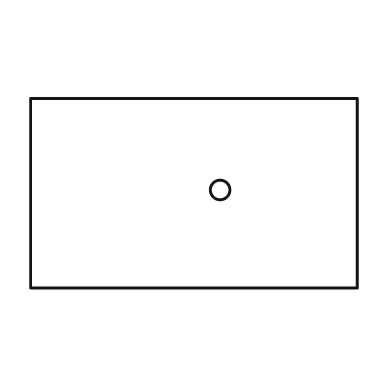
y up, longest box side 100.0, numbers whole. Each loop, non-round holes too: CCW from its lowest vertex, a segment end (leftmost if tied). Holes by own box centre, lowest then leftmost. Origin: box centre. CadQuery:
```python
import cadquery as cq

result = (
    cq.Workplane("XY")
    .moveTo(-50.0, -29.0)
    .lineTo(50.0, -29.0)
    .lineTo(50.0, 29.0)
    .lineTo(-50.0, 29.0)
    .close()
    .moveTo(8.0, 1.0)
    .circle(3.0)
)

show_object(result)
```